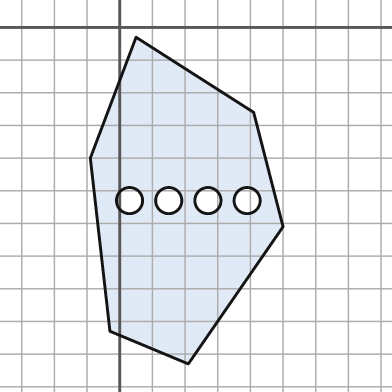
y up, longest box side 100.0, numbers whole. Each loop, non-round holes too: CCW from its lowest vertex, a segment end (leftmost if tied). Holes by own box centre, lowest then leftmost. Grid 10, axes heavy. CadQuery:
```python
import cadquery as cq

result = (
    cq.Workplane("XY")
    .moveTo(21.0, -103.0)
    .lineTo(50.0, -61.0)
    .lineTo(41.0, -26.0)
    .lineTo(5.0, -3.0)
    .lineTo(-9.0, -40.0)
    .lineTo(-3.0, -93.0)
    .close()
    .moveTo(3.0, -53.0)
    .circle(4.0)
    .moveTo(15.0, -53.0)
    .circle(4.0)
    .moveTo(27.0, -53.0)
    .circle(4.0)
    .moveTo(39.0, -53.0)
    .circle(4.0)
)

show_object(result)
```